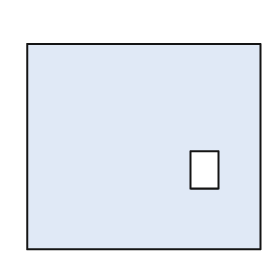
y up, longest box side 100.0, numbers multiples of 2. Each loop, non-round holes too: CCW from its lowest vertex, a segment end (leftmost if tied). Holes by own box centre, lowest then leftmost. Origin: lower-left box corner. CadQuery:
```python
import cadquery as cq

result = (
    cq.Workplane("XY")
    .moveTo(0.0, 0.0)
    .lineTo(100.0, 0.0)
    .lineTo(100.0, 88.0)
    .lineTo(0.0, 88.0)
    .close()
    .moveTo(70.0, 26.0)
    .lineTo(82.0, 26.0)
    .lineTo(82.0, 42.0)
    .lineTo(70.0, 42.0)
    .close()
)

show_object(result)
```